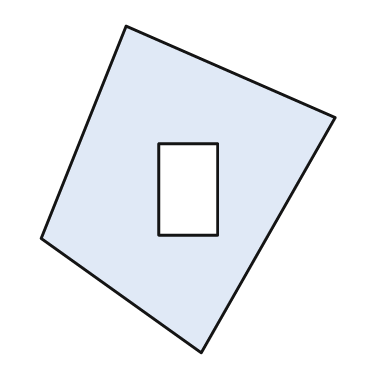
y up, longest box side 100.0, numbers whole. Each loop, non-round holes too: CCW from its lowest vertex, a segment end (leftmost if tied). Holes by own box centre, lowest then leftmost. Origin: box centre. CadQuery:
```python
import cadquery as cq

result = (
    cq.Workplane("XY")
    .moveTo(4.0, -50.0)
    .lineTo(45.0, 22.0)
    .lineTo(-19.0, 50.0)
    .lineTo(-45.0, -15.0)
    .close()
    .moveTo(-9.0, -14.0)
    .lineTo(9.0, -14.0)
    .lineTo(9.0, 14.0)
    .lineTo(-9.0, 14.0)
    .close()
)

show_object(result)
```